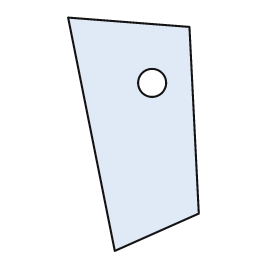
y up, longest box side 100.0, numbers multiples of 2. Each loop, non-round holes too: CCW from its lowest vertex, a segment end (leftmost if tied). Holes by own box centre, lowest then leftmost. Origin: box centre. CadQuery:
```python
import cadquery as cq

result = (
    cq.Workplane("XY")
    .moveTo(-8.0, -50.0)
    .lineTo(28.0, -34.0)
    .lineTo(24.0, 46.0)
    .lineTo(-28.0, 50.0)
    .close()
    .moveTo(8.0, 22.0)
    .circle(6.0)
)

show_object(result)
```